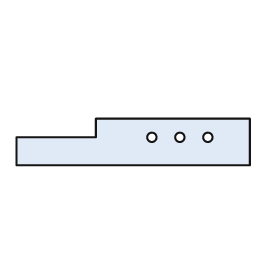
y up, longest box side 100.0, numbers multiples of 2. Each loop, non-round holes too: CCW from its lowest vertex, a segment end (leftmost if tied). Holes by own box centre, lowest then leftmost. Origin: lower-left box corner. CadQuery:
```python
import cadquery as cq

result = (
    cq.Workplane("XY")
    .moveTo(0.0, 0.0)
    .lineTo(100.0, 0.0)
    .lineTo(100.0, 20.0)
    .lineTo(34.0, 20.0)
    .lineTo(34.0, 12.0)
    .lineTo(0.0, 12.0)
    .close()
    .moveTo(58.0, 12.0)
    .circle(2.0)
    .moveTo(70.0, 12.0)
    .circle(2.0)
    .moveTo(82.0, 12.0)
    .circle(2.0)
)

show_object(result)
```